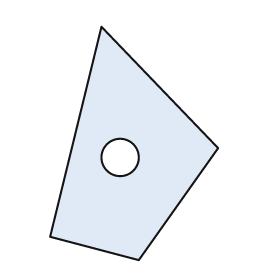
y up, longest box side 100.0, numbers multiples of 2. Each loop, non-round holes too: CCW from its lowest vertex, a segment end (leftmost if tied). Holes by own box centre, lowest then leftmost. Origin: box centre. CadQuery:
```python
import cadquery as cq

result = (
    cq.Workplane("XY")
    .moveTo(2.0, -50.0)
    .lineTo(36.0, -2.0)
    .lineTo(-14.0, 50.0)
    .lineTo(-36.0, -40.0)
    .close()
    .moveTo(-6.0, -6.0)
    .circle(8.0)
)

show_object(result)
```